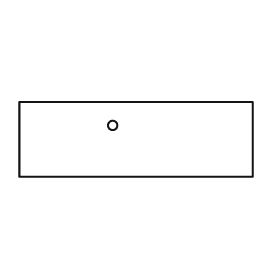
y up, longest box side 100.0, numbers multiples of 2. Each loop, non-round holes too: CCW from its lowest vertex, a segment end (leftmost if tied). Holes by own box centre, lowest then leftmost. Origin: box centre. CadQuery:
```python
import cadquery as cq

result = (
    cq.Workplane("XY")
    .moveTo(-50.0, -16.0)
    .lineTo(50.0, -16.0)
    .lineTo(50.0, 16.0)
    .lineTo(-50.0, 16.0)
    .close()
    .moveTo(-10.0, 6.0)
    .circle(2.0)
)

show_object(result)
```